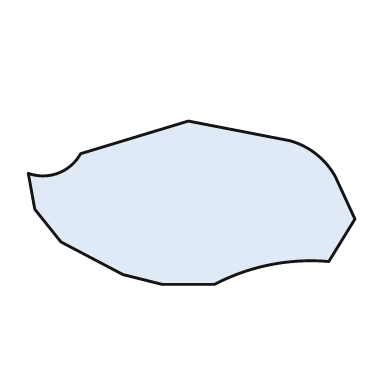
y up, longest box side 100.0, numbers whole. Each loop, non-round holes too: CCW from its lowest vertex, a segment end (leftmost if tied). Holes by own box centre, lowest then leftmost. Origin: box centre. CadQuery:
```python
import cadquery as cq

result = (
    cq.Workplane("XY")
    .moveTo(-9.0, -25.0)
    .lineTo(7.0, -25.0)
    .threePointArc((24.0, -19.0), (42.0, -18.0))
    .lineTo(50.0, -5.0)
    .lineTo(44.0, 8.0)
    .threePointArc((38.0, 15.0), (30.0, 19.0))
    .lineTo(-1.0, 25.0)
    .lineTo(-34.0, 15.0)
    .threePointArc((-41.0, 9.0), (-50.0, 9.0))
    .lineTo(-48.0, -2.0)
    .lineTo(-40.0, -12.0)
    .lineTo(-21.0, -22.0)
    .close()
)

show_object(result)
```